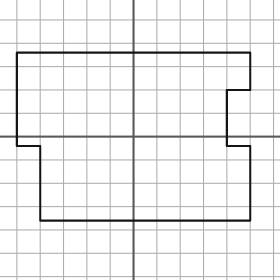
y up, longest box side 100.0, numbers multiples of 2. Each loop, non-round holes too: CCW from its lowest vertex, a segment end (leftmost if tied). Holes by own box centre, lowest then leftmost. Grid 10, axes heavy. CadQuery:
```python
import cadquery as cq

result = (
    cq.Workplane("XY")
    .moveTo(-40.0, -36.0)
    .lineTo(50.0, -36.0)
    .lineTo(50.0, -4.0)
    .lineTo(40.0, -4.0)
    .lineTo(40.0, 20.0)
    .lineTo(50.0, 20.0)
    .lineTo(50.0, 36.0)
    .lineTo(-50.0, 36.0)
    .lineTo(-50.0, -4.0)
    .lineTo(-40.0, -4.0)
    .close()
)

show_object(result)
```